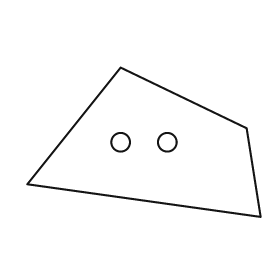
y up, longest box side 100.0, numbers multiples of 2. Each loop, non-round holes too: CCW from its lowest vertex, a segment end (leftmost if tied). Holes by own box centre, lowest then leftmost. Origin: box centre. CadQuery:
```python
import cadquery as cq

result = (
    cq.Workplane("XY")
    .moveTo(50.0, -32.0)
    .lineTo(44.0, 6.0)
    .lineTo(-10.0, 32.0)
    .lineTo(-50.0, -18.0)
    .close()
    .moveTo(-10.0, 0.0)
    .circle(4.0)
    .moveTo(10.0, 0.0)
    .circle(4.0)
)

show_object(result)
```